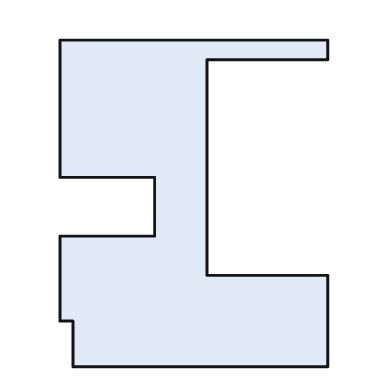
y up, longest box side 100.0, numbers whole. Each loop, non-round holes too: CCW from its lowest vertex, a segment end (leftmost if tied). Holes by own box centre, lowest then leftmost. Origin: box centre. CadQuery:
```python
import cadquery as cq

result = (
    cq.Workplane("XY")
    .moveTo(-37.0, -50.0)
    .lineTo(41.0, -50.0)
    .lineTo(41.0, -22.0)
    .lineTo(4.0, -22.0)
    .lineTo(4.0, 44.0)
    .lineTo(41.0, 44.0)
    .lineTo(41.0, 50.0)
    .lineTo(-41.0, 50.0)
    .lineTo(-41.0, 8.0)
    .lineTo(-12.0, 8.0)
    .lineTo(-12.0, -10.0)
    .lineTo(-41.0, -10.0)
    .lineTo(-41.0, -36.0)
    .lineTo(-37.0, -36.0)
    .close()
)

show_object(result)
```